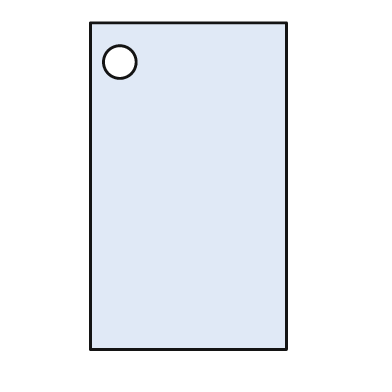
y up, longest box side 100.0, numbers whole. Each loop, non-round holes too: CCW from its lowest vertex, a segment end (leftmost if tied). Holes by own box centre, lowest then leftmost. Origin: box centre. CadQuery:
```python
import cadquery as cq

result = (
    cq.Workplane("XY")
    .moveTo(-30.0, -50.0)
    .lineTo(30.0, -50.0)
    .lineTo(30.0, 50.0)
    .lineTo(-30.0, 50.0)
    .close()
    .moveTo(-21.0, 38.0)
    .circle(5.0)
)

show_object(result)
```